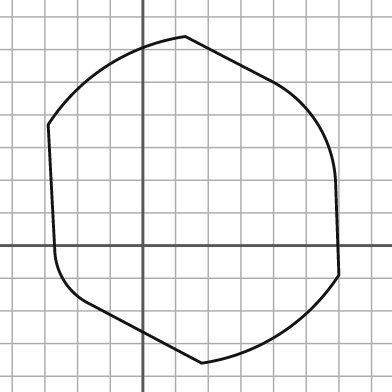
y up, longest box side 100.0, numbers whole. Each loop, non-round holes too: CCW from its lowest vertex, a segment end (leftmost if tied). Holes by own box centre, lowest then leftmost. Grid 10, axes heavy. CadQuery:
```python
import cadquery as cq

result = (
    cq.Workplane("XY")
    .moveTo(18.0, -36.0)
    .threePointArc((42.0, -27.0), (60.0, -9.0))
    .lineTo(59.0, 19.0)
    .threePointArc((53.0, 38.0), (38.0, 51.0))
    .lineTo(13.0, 64.0)
    .threePointArc((-11.0, 55.0), (-29.0, 37.0))
    .lineTo(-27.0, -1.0)
    .threePointArc((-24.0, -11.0), (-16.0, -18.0))
    .close()
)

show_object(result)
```